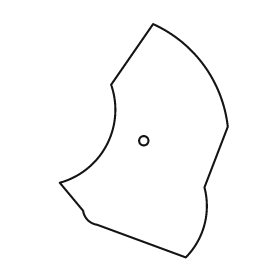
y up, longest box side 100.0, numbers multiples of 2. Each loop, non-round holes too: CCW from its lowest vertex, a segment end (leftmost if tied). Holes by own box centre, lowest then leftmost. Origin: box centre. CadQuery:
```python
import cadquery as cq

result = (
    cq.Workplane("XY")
    .moveTo(18.0, -50.0)
    .threePointArc((26.0, -36.0), (26.0, -20.0))
    .lineTo(36.0, 6.0)
    .threePointArc((26.0, 32.0), (4.0, 50.0))
    .lineTo(-14.0, 24.0)
    .threePointArc((-16.0, -2.0), (-36.0, -18.0))
    .lineTo(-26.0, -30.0)
    .threePointArc((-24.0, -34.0), (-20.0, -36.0))
    .close()
    .moveTo(0.0, 0.0)
    .circle(2.0)
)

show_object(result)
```